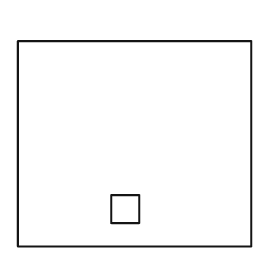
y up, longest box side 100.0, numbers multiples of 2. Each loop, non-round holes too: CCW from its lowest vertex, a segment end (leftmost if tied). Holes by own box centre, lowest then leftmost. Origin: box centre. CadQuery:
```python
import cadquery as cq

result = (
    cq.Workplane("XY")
    .moveTo(-50.0, -44.0)
    .lineTo(50.0, -44.0)
    .lineTo(50.0, 44.0)
    .lineTo(-50.0, 44.0)
    .close()
    .moveTo(-10.0, -34.0)
    .lineTo(2.0, -34.0)
    .lineTo(2.0, -22.0)
    .lineTo(-10.0, -22.0)
    .close()
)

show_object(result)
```